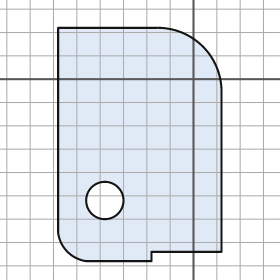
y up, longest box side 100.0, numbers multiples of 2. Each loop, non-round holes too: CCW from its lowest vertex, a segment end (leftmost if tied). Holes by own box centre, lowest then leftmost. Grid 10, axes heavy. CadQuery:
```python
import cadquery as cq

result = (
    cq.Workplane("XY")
    .moveTo(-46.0, -78.0)
    .lineTo(-18.0, -78.0)
    .lineTo(-18.0, -74.0)
    .lineTo(12.0, -74.0)
    .lineTo(12.0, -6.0)
    .threePointArc((4.0, 14.0), (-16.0, 22.0))
    .lineTo(-58.0, 22.0)
    .lineTo(-58.0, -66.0)
    .threePointArc((-54.0, -74.0), (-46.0, -78.0))
    .close()
    .moveTo(-38.0, -52.0)
    .circle(8.0)
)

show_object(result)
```